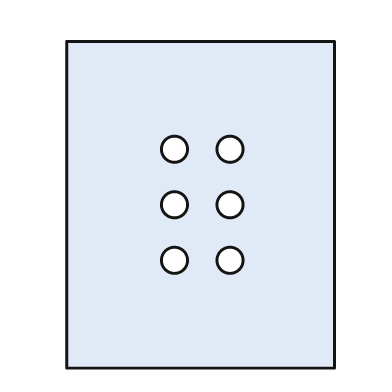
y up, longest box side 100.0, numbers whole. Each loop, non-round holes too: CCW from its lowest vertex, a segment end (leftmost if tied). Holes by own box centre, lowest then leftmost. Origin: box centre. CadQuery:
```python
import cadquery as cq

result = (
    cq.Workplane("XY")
    .moveTo(-41.0, -50.0)
    .lineTo(41.0, -50.0)
    .lineTo(41.0, 50.0)
    .lineTo(-41.0, 50.0)
    .close()
    .moveTo(-8.0, -17.0)
    .circle(4.0)
    .moveTo(9.0, -17.0)
    .circle(4.0)
    .moveTo(-8.0, 0.0)
    .circle(4.0)
    .moveTo(9.0, 0.0)
    .circle(4.0)
    .moveTo(-8.0, 17.0)
    .circle(4.0)
    .moveTo(9.0, 17.0)
    .circle(4.0)
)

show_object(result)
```